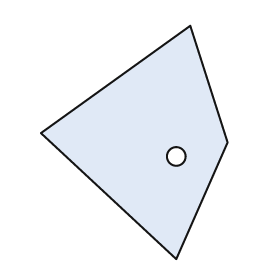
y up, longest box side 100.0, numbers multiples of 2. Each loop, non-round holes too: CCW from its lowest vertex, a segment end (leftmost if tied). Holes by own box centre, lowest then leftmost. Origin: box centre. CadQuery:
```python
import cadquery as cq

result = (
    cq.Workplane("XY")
    .moveTo(18.0, -50.0)
    .lineTo(40.0, 0.0)
    .lineTo(24.0, 50.0)
    .lineTo(-40.0, 4.0)
    .close()
    .moveTo(18.0, -6.0)
    .circle(4.0)
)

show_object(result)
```